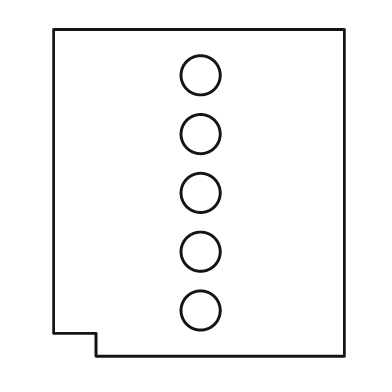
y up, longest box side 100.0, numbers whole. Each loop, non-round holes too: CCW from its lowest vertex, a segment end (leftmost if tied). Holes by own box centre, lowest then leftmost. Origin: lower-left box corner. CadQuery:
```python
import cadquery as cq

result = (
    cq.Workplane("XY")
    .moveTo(13.0, 0.0)
    .lineTo(89.0, 0.0)
    .lineTo(89.0, 100.0)
    .lineTo(0.0, 100.0)
    .lineTo(0.0, 7.0)
    .lineTo(13.0, 7.0)
    .close()
    .moveTo(45.0, 14.0)
    .circle(6.0)
    .moveTo(45.0, 32.0)
    .circle(6.0)
    .moveTo(45.0, 50.0)
    .circle(6.0)
    .moveTo(45.0, 68.0)
    .circle(6.0)
    .moveTo(45.0, 86.0)
    .circle(6.0)
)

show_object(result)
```